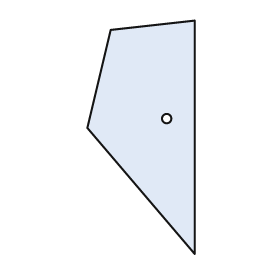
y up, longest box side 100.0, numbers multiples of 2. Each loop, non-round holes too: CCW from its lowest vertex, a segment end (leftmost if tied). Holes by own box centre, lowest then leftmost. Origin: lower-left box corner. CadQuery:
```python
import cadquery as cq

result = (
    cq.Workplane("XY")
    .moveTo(46.0, 0.0)
    .lineTo(46.0, 100.0)
    .lineTo(10.0, 96.0)
    .lineTo(0.0, 54.0)
    .close()
    .moveTo(34.0, 58.0)
    .circle(2.0)
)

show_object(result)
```